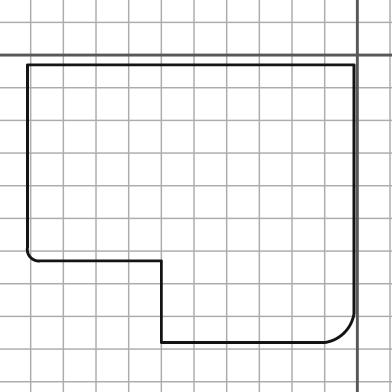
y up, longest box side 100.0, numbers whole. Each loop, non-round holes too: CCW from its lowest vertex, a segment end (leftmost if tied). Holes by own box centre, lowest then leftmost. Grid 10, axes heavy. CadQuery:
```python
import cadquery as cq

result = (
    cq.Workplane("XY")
    .moveTo(-60.0, -88.0)
    .lineTo(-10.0, -88.0)
    .threePointArc((-4.0, -85.0), (-1.0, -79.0))
    .lineTo(-1.0, -3.0)
    .lineTo(-101.0, -3.0)
    .lineTo(-101.0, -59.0)
    .threePointArc((-100.0, -62.0), (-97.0, -63.0))
    .lineTo(-60.0, -63.0)
    .close()
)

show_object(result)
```